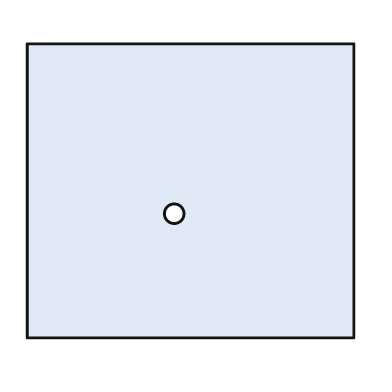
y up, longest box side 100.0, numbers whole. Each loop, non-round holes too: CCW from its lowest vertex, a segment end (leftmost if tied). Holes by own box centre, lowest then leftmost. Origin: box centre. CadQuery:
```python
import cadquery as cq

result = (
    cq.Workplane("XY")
    .moveTo(-50.0, -45.0)
    .lineTo(50.0, -45.0)
    .lineTo(50.0, 45.0)
    .lineTo(-50.0, 45.0)
    .close()
    .moveTo(-5.0, -7.0)
    .circle(3.0)
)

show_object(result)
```